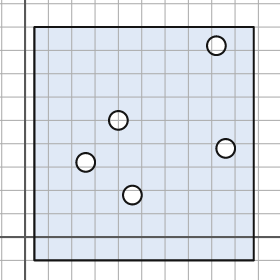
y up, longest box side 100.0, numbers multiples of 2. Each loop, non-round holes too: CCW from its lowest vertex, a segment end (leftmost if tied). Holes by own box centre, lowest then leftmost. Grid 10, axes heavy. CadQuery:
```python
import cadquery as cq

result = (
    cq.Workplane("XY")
    .moveTo(4.0, -10.0)
    .lineTo(98.0, -10.0)
    .lineTo(98.0, 90.0)
    .lineTo(4.0, 90.0)
    .close()
    .moveTo(46.0, 18.0)
    .circle(4.0)
    .moveTo(26.0, 32.0)
    .circle(4.0)
    .moveTo(86.0, 38.0)
    .circle(4.0)
    .moveTo(40.0, 50.0)
    .circle(4.0)
    .moveTo(82.0, 82.0)
    .circle(4.0)
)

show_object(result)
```